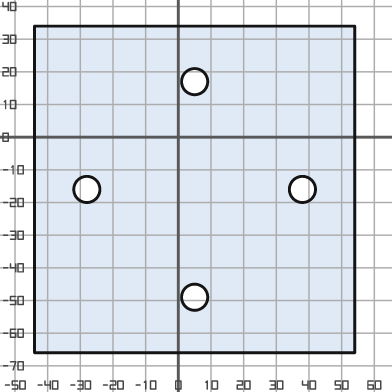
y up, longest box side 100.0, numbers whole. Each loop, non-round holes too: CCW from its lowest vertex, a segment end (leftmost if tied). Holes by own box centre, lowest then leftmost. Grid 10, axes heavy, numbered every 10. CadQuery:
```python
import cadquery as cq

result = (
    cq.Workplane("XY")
    .moveTo(-44.0, -66.0)
    .lineTo(54.0, -66.0)
    .lineTo(54.0, 34.0)
    .lineTo(-44.0, 34.0)
    .close()
    .moveTo(5.0, -49.0)
    .circle(4.0)
    .moveTo(-28.0, -16.0)
    .circle(4.0)
    .moveTo(38.0, -16.0)
    .circle(4.0)
    .moveTo(5.0, 17.0)
    .circle(4.0)
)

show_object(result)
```